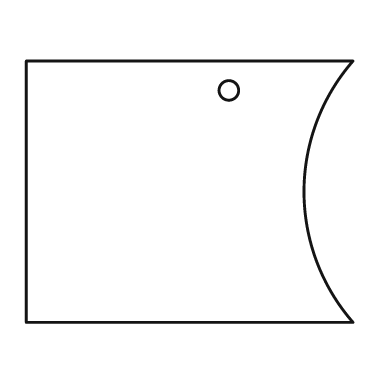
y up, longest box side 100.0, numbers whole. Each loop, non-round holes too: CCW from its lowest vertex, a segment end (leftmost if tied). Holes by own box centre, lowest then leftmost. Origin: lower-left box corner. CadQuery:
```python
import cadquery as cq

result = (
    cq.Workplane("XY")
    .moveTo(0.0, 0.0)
    .lineTo(100.0, 0.0)
    .threePointArc((85.0, 40.0), (100.0, 80.0))
    .lineTo(0.0, 80.0)
    .close()
    .moveTo(62.0, 71.0)
    .circle(3.0)
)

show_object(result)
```